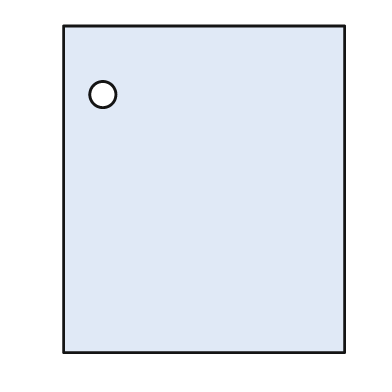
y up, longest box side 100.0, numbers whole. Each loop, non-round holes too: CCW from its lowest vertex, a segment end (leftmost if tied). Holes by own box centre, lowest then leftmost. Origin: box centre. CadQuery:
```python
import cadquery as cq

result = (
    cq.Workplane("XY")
    .moveTo(-43.0, -50.0)
    .lineTo(43.0, -50.0)
    .lineTo(43.0, 50.0)
    .lineTo(-43.0, 50.0)
    .close()
    .moveTo(-31.0, 29.0)
    .circle(4.0)
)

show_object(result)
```